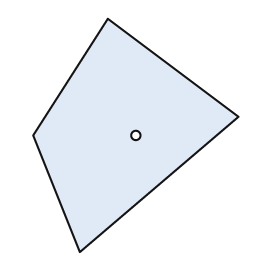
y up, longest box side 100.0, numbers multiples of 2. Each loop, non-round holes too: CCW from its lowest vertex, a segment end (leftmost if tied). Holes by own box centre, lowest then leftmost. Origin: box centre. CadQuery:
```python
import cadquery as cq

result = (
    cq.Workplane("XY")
    .moveTo(-24.0, -50.0)
    .lineTo(44.0, 8.0)
    .lineTo(-12.0, 50.0)
    .lineTo(-44.0, 0.0)
    .close()
    .moveTo(0.0, 0.0)
    .circle(2.0)
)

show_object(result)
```